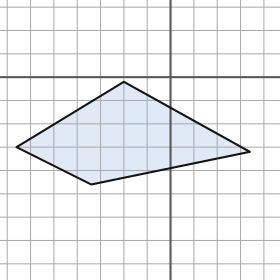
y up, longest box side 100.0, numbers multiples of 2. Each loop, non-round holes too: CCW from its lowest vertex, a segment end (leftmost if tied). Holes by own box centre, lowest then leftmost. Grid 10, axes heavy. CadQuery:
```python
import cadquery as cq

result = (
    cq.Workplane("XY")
    .moveTo(-34.0, -46.0)
    .lineTo(34.0, -32.0)
    .lineTo(-20.0, -2.0)
    .lineTo(-66.0, -30.0)
    .close()
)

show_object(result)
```